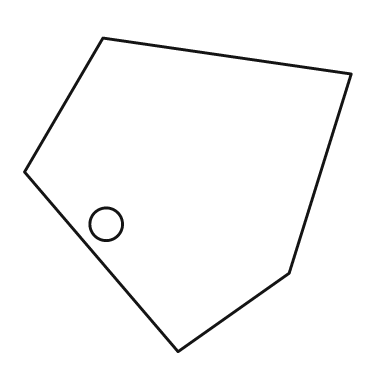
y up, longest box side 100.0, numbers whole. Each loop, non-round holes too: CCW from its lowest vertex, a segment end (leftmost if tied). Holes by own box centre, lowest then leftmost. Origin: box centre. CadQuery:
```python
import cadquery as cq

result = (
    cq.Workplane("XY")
    .moveTo(-3.0, -48.0)
    .lineTo(31.0, -24.0)
    .lineTo(50.0, 37.0)
    .lineTo(-26.0, 48.0)
    .lineTo(-50.0, 7.0)
    .close()
    .moveTo(-25.0, -9.0)
    .circle(5.0)
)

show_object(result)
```